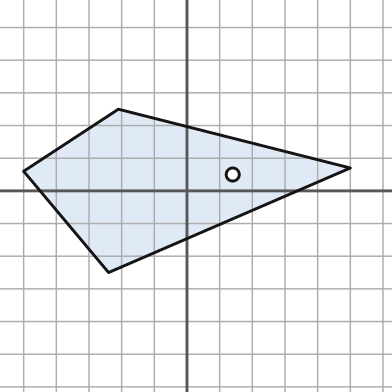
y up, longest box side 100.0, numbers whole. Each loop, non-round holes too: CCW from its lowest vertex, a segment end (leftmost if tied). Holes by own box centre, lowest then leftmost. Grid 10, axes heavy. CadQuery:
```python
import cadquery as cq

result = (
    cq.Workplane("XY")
    .moveTo(-24.0, -25.0)
    .lineTo(50.0, 7.0)
    .lineTo(-21.0, 25.0)
    .lineTo(-50.0, 6.0)
    .close()
    .moveTo(14.0, 5.0)
    .circle(2.0)
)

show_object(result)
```